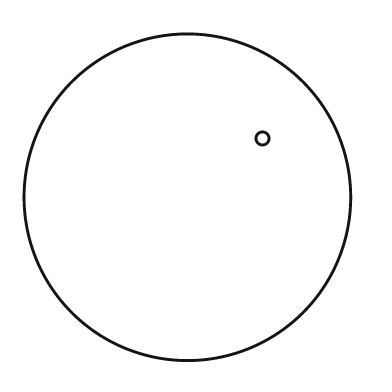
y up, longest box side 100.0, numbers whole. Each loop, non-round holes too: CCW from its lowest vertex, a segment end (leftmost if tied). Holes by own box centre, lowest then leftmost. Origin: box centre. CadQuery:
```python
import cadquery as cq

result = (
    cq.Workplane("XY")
    .moveTo(0.0, 0.0)
    .circle(50.0)
    .moveTo(23.0, 18.0)
    .circle(2.0)
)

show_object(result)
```